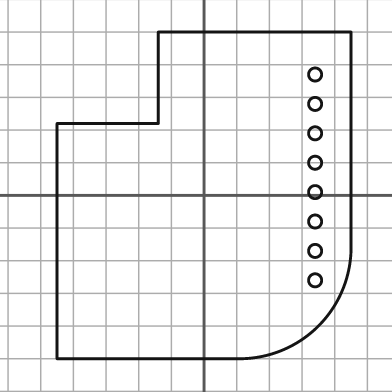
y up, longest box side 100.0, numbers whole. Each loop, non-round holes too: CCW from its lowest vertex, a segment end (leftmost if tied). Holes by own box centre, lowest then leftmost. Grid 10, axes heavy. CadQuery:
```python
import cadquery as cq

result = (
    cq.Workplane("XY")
    .moveTo(-45.0, -50.0)
    .lineTo(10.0, -50.0)
    .threePointArc((35.0, -40.0), (45.0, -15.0))
    .lineTo(45.0, 50.0)
    .lineTo(-14.0, 50.0)
    .lineTo(-14.0, 22.0)
    .lineTo(-45.0, 22.0)
    .close()
    .moveTo(34.0, -26.0)
    .circle(2.0)
    .moveTo(34.0, -17.0)
    .circle(2.0)
    .moveTo(34.0, -8.0)
    .circle(2.0)
    .moveTo(34.0, 1.0)
    .circle(2.0)
    .moveTo(34.0, 10.0)
    .circle(2.0)
    .moveTo(34.0, 19.0)
    .circle(2.0)
    .moveTo(34.0, 28.0)
    .circle(2.0)
    .moveTo(34.0, 37.0)
    .circle(2.0)
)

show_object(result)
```